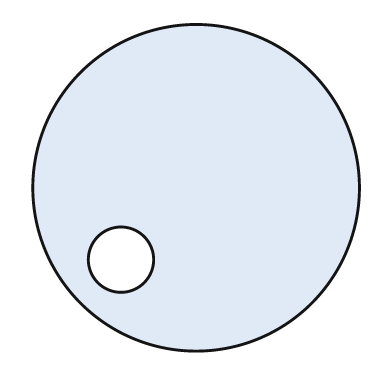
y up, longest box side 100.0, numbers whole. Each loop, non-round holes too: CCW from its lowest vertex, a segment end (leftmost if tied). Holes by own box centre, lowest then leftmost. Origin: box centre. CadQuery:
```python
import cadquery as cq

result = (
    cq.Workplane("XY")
    .moveTo(0.0, 0.0)
    .circle(50.0)
    .moveTo(-23.0, -22.0)
    .circle(10.0)
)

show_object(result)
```